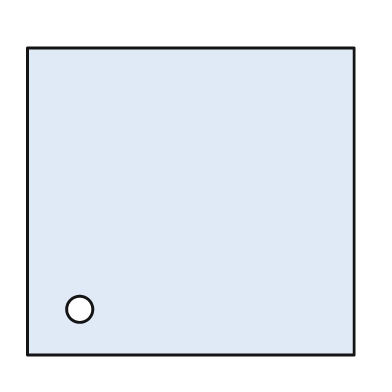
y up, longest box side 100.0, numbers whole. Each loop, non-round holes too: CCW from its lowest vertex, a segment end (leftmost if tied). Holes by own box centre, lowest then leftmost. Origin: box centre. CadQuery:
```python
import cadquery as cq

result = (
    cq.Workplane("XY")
    .moveTo(-50.0, -47.0)
    .lineTo(50.0, -47.0)
    .lineTo(50.0, 47.0)
    .lineTo(-50.0, 47.0)
    .close()
    .moveTo(-34.0, -33.0)
    .circle(4.0)
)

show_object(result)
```